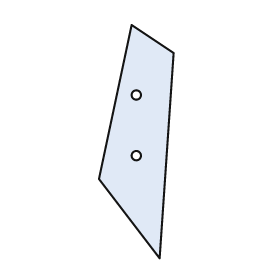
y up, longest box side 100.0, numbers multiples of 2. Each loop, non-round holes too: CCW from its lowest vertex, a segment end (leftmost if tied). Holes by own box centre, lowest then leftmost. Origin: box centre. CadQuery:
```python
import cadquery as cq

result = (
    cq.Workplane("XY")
    .moveTo(10.0, -50.0)
    .lineTo(16.0, 38.0)
    .lineTo(-2.0, 50.0)
    .lineTo(-16.0, -16.0)
    .close()
    .moveTo(0.0, -6.0)
    .circle(2.0)
    .moveTo(0.0, 20.0)
    .circle(2.0)
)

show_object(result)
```